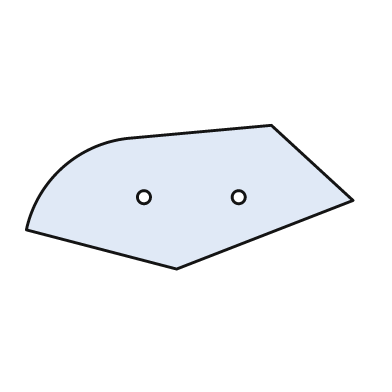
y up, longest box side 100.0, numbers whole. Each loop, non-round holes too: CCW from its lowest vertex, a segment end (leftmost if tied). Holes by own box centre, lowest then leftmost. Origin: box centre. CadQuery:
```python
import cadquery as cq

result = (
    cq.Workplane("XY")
    .moveTo(-4.0, -22.0)
    .lineTo(50.0, -1.0)
    .lineTo(25.0, 22.0)
    .lineTo(-19.0, 18.0)
    .threePointArc((-39.0, 9.0), (-50.0, -10.0))
    .close()
    .moveTo(-14.0, 0.0)
    .circle(2.0)
    .moveTo(15.0, 0.0)
    .circle(2.0)
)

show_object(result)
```